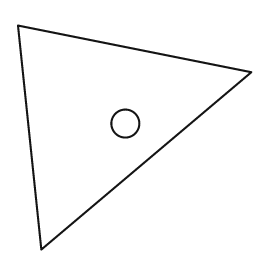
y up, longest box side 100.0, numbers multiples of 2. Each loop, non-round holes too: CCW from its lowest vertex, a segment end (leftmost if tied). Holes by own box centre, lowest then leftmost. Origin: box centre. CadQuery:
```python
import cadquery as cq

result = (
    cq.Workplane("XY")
    .moveTo(-40.0, -48.0)
    .lineTo(50.0, 28.0)
    .lineTo(-50.0, 48.0)
    .close()
    .moveTo(-4.0, 6.0)
    .circle(6.0)
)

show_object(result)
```